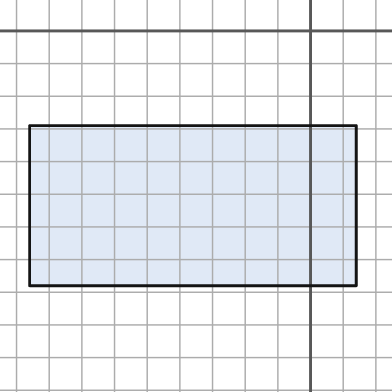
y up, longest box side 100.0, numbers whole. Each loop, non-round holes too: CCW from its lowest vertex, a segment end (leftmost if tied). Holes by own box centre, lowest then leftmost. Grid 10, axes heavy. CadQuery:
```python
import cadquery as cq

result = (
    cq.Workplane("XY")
    .moveTo(-86.0, -78.0)
    .lineTo(14.0, -78.0)
    .lineTo(14.0, -29.0)
    .lineTo(-86.0, -29.0)
    .close()
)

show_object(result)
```